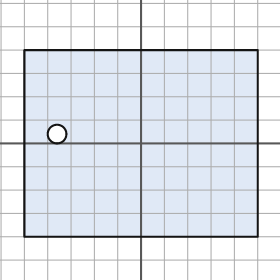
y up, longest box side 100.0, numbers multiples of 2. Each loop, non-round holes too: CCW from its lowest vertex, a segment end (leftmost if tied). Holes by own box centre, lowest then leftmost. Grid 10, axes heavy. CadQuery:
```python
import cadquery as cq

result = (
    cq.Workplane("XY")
    .moveTo(-50.0, -40.0)
    .lineTo(50.0, -40.0)
    .lineTo(50.0, 40.0)
    .lineTo(-50.0, 40.0)
    .close()
    .moveTo(-36.0, 4.0)
    .circle(4.0)
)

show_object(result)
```